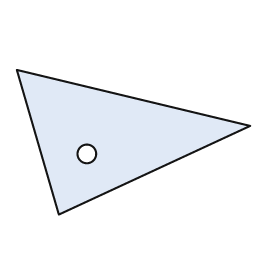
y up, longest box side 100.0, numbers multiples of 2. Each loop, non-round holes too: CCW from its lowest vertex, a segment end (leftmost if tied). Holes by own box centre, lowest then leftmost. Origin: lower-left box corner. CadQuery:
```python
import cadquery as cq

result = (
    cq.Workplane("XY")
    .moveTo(18.0, 0.0)
    .lineTo(100.0, 38.0)
    .lineTo(0.0, 62.0)
    .close()
    .moveTo(30.0, 26.0)
    .circle(4.0)
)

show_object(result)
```